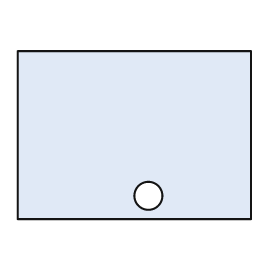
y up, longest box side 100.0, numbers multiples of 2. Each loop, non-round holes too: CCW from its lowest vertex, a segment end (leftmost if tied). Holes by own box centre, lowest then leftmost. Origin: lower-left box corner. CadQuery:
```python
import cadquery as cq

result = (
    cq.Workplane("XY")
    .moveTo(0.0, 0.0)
    .lineTo(100.0, 0.0)
    .lineTo(100.0, 72.0)
    .lineTo(0.0, 72.0)
    .close()
    .moveTo(56.0, 10.0)
    .circle(6.0)
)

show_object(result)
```